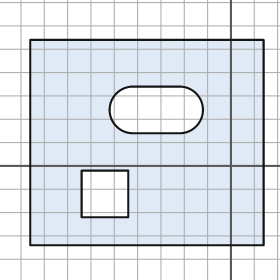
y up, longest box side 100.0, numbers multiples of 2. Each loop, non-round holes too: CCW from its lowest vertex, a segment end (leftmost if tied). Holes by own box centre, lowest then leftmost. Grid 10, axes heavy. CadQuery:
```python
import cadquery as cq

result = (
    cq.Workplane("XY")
    .moveTo(-86.0, -34.0)
    .lineTo(14.0, -34.0)
    .lineTo(14.0, 54.0)
    .lineTo(-86.0, 54.0)
    .close()
    .moveTo(-64.0, -22.0)
    .lineTo(-44.0, -22.0)
    .lineTo(-44.0, -2.0)
    .lineTo(-64.0, -2.0)
    .close()
    .moveTo(-42.0, 14.0)
    .lineTo(-22.0, 14.0)
    .threePointArc((-12.0, 24.0), (-22.0, 34.0))
    .lineTo(-42.0, 34.0)
    .threePointArc((-52.0, 24.0), (-42.0, 14.0))
    .close()
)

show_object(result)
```